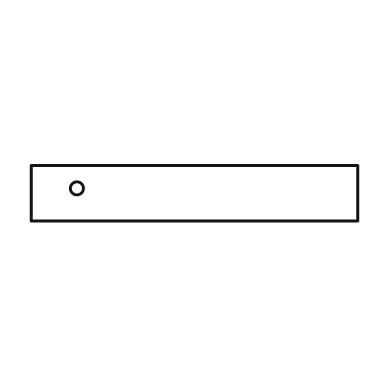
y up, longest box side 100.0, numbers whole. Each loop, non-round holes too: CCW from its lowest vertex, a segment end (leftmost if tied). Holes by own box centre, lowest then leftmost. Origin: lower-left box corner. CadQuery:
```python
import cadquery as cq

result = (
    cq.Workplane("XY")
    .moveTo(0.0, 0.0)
    .lineTo(100.0, 0.0)
    .lineTo(100.0, 17.0)
    .lineTo(0.0, 17.0)
    .close()
    .moveTo(14.0, 10.0)
    .circle(2.0)
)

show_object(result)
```